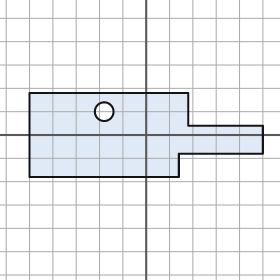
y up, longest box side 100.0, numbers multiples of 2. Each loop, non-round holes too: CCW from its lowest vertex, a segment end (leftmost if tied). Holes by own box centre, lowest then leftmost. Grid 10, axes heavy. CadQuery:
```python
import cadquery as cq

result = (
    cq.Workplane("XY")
    .moveTo(-50.0, -18.0)
    .lineTo(14.0, -18.0)
    .lineTo(14.0, -8.0)
    .lineTo(50.0, -8.0)
    .lineTo(50.0, 4.0)
    .lineTo(18.0, 4.0)
    .lineTo(18.0, 18.0)
    .lineTo(-50.0, 18.0)
    .close()
    .moveTo(-18.0, 10.0)
    .circle(4.0)
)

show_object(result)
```